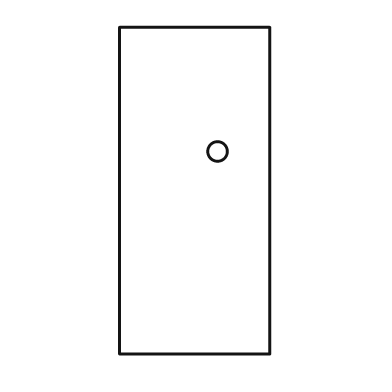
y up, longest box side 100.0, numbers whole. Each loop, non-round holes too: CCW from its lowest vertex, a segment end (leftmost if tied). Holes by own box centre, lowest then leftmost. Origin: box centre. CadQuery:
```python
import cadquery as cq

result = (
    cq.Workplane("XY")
    .moveTo(-23.0, -50.0)
    .lineTo(23.0, -50.0)
    .lineTo(23.0, 50.0)
    .lineTo(-23.0, 50.0)
    .close()
    .moveTo(7.0, 12.0)
    .circle(3.0)
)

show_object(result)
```